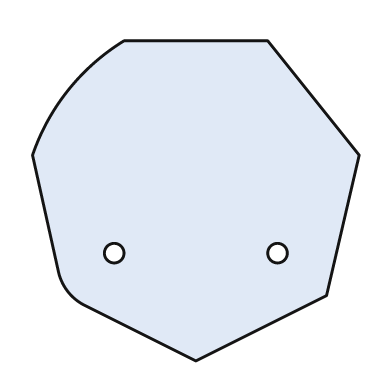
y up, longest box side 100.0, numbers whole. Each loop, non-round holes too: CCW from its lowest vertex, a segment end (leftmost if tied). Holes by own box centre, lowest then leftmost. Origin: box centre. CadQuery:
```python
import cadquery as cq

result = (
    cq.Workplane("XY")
    .moveTo(0.0, -49.0)
    .lineTo(40.0, -29.0)
    .lineTo(50.0, 14.0)
    .lineTo(22.0, 49.0)
    .lineTo(-22.0, 49.0)
    .threePointArc((-39.0, 34.0), (-50.0, 14.0))
    .lineTo(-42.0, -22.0)
    .threePointArc((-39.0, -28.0), (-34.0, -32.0))
    .close()
    .moveTo(-25.0, -16.0)
    .circle(3.0)
    .moveTo(25.0, -16.0)
    .circle(3.0)
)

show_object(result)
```